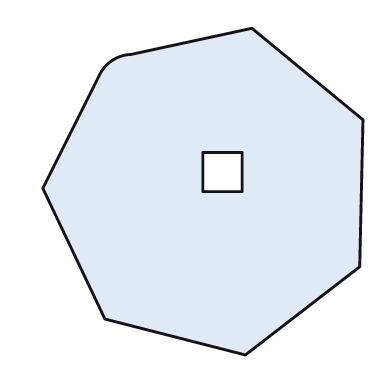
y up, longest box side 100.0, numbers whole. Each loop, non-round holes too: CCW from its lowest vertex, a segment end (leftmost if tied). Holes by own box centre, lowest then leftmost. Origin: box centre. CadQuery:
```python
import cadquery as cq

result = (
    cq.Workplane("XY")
    .moveTo(13.0, -50.0)
    .lineTo(48.0, -23.0)
    .lineTo(49.0, 22.0)
    .lineTo(15.0, 50.0)
    .lineTo(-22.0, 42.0)
    .threePointArc((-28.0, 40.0), (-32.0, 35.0))
    .lineTo(-49.0, 1.0)
    .lineTo(-30.0, -39.0)
    .close()
    .moveTo(0.0, 0.0)
    .lineTo(12.0, 0.0)
    .lineTo(12.0, 12.0)
    .lineTo(0.0, 12.0)
    .close()
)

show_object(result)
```